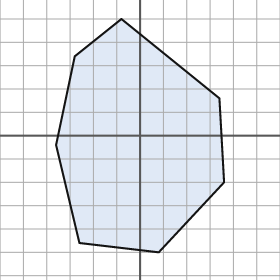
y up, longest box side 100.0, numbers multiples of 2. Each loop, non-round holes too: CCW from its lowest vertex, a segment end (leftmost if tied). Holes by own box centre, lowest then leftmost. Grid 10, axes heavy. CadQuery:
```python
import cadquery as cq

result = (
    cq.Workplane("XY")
    .moveTo(8.0, -50.0)
    .lineTo(36.0, -20.0)
    .lineTo(34.0, 16.0)
    .lineTo(-8.0, 50.0)
    .lineTo(-28.0, 34.0)
    .lineTo(-36.0, -4.0)
    .lineTo(-26.0, -46.0)
    .close()
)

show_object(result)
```